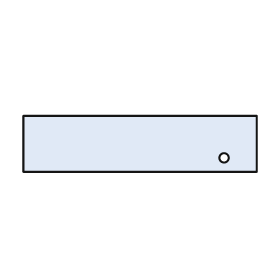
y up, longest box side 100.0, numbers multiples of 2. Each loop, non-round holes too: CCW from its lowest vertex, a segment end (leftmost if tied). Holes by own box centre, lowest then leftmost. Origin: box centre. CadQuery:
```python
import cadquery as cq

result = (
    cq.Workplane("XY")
    .moveTo(-50.0, -12.0)
    .lineTo(50.0, -12.0)
    .lineTo(50.0, 12.0)
    .lineTo(-50.0, 12.0)
    .close()
    .moveTo(36.0, -6.0)
    .circle(2.0)
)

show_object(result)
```